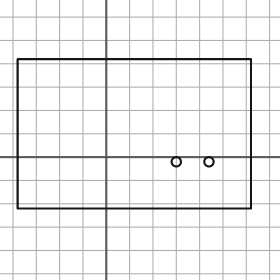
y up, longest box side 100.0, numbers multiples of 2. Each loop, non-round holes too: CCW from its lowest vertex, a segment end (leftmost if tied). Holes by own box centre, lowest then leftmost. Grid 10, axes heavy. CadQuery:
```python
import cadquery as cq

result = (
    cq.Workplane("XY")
    .moveTo(-38.0, -22.0)
    .lineTo(62.0, -22.0)
    .lineTo(62.0, 42.0)
    .lineTo(-38.0, 42.0)
    .close()
    .moveTo(30.0, -2.0)
    .circle(2.0)
    .moveTo(44.0, -2.0)
    .circle(2.0)
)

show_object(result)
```